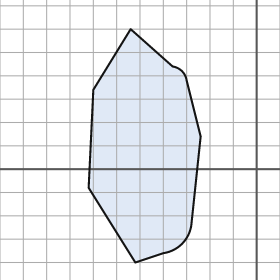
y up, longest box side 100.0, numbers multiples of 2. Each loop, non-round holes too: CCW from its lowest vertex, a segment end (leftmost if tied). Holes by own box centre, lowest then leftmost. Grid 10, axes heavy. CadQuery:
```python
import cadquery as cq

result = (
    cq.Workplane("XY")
    .moveTo(-52.0, -40.0)
    .lineTo(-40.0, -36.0)
    .threePointArc((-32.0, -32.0), (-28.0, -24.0))
    .lineTo(-24.0, 14.0)
    .lineTo(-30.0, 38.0)
    .threePointArc((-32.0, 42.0), (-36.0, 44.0))
    .lineTo(-54.0, 60.0)
    .lineTo(-70.0, 34.0)
    .lineTo(-72.0, -8.0)
    .close()
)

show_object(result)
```